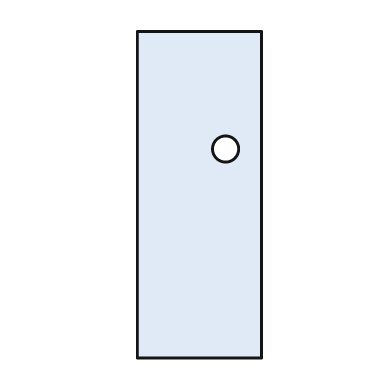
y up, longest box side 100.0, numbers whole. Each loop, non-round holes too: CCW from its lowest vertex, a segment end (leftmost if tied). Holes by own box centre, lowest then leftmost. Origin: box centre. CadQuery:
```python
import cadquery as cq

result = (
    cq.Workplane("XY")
    .moveTo(-19.0, -50.0)
    .lineTo(19.0, -50.0)
    .lineTo(19.0, 50.0)
    .lineTo(-19.0, 50.0)
    .close()
    .moveTo(8.0, 14.0)
    .circle(4.0)
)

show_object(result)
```